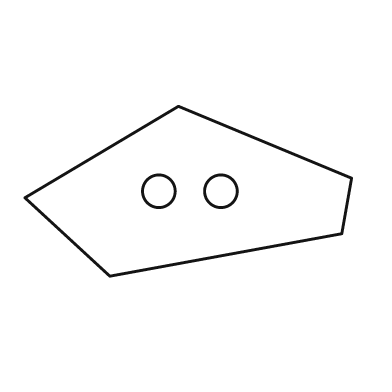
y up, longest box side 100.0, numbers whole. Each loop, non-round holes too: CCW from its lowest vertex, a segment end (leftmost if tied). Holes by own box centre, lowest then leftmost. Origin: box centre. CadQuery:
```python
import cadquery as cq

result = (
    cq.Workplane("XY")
    .moveTo(-24.0, -26.0)
    .lineTo(47.0, -13.0)
    .lineTo(50.0, 4.0)
    .lineTo(-3.0, 26.0)
    .lineTo(-50.0, -2.0)
    .close()
    .moveTo(-9.0, 0.0)
    .circle(5.0)
    .moveTo(10.0, 0.0)
    .circle(5.0)
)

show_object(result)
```